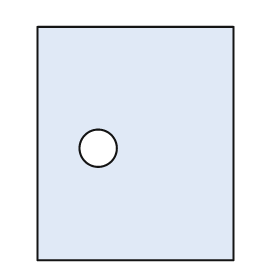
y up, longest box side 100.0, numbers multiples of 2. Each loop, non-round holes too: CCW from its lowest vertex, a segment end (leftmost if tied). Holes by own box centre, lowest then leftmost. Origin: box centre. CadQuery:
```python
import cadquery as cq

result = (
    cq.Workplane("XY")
    .moveTo(-42.0, -50.0)
    .lineTo(42.0, -50.0)
    .lineTo(42.0, 50.0)
    .lineTo(-42.0, 50.0)
    .close()
    .moveTo(-16.0, -2.0)
    .circle(8.0)
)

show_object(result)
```